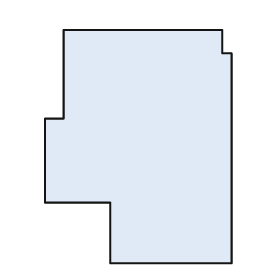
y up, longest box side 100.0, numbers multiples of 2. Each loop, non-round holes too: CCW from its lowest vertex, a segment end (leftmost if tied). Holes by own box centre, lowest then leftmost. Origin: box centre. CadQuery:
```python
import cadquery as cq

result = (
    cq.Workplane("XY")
    .moveTo(-12.0, -50.0)
    .lineTo(40.0, -50.0)
    .lineTo(40.0, 40.0)
    .lineTo(36.0, 40.0)
    .lineTo(36.0, 50.0)
    .lineTo(-32.0, 50.0)
    .lineTo(-32.0, 12.0)
    .lineTo(-40.0, 12.0)
    .lineTo(-40.0, -24.0)
    .lineTo(-12.0, -24.0)
    .close()
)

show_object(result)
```